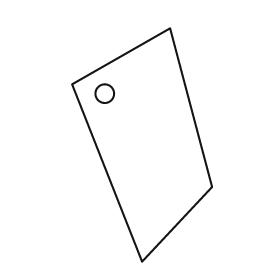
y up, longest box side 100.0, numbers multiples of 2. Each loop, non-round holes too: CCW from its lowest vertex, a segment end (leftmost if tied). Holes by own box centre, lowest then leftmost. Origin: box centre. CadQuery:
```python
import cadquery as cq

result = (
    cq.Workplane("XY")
    .moveTo(0.0, -50.0)
    .lineTo(30.0, -18.0)
    .lineTo(12.0, 50.0)
    .lineTo(-30.0, 26.0)
    .close()
    .moveTo(-16.0, 22.0)
    .circle(4.0)
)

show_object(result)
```